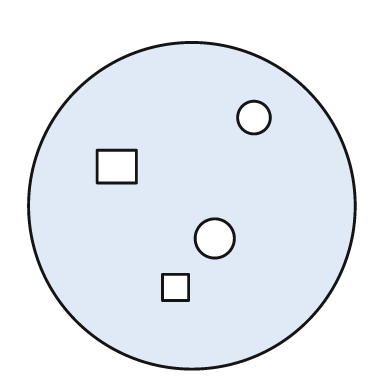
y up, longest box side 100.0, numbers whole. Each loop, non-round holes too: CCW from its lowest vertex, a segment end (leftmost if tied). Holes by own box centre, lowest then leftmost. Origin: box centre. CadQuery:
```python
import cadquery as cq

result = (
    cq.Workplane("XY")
    .moveTo(0.0, 0.0)
    .circle(50.0)
    .moveTo(-9.0, -29.0)
    .lineTo(-1.0, -29.0)
    .lineTo(-1.0, -21.0)
    .lineTo(-9.0, -21.0)
    .close()
    .moveTo(7.0, -10.0)
    .circle(6.0)
    .moveTo(-29.0, 7.0)
    .lineTo(-17.0, 7.0)
    .lineTo(-17.0, 17.0)
    .lineTo(-29.0, 17.0)
    .close()
    .moveTo(19.0, 27.0)
    .circle(5.0)
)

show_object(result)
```